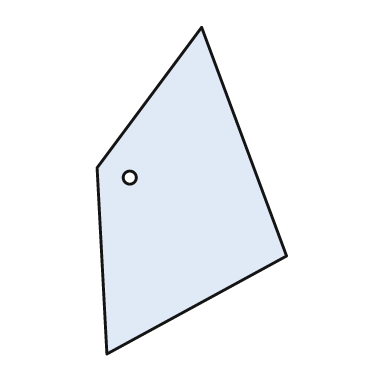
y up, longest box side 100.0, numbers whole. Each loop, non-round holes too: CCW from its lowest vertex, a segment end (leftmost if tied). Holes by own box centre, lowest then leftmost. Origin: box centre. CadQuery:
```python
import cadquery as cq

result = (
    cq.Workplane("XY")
    .moveTo(-26.0, -50.0)
    .lineTo(29.0, -20.0)
    .lineTo(3.0, 50.0)
    .lineTo(-29.0, 7.0)
    .close()
    .moveTo(-19.0, 4.0)
    .circle(2.0)
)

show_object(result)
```